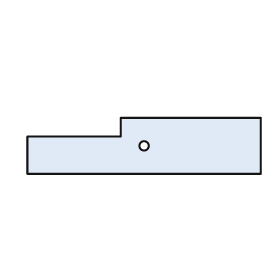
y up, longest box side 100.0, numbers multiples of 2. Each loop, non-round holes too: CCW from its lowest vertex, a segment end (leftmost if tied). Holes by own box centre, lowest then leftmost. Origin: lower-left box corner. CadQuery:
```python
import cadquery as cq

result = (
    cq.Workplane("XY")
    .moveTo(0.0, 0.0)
    .lineTo(100.0, 0.0)
    .lineTo(100.0, 24.0)
    .lineTo(40.0, 24.0)
    .lineTo(40.0, 16.0)
    .lineTo(0.0, 16.0)
    .close()
    .moveTo(50.0, 12.0)
    .circle(2.0)
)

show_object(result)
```